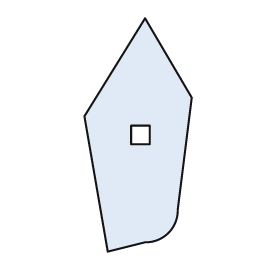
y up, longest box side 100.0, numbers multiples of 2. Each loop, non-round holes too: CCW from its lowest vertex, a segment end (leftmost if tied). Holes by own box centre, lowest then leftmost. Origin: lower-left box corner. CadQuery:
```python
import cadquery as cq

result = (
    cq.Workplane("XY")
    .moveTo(10.0, 0.0)
    .lineTo(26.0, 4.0)
    .threePointArc((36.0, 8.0), (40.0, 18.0))
    .lineTo(46.0, 66.0)
    .lineTo(26.0, 100.0)
    .lineTo(0.0, 58.0)
    .close()
    .moveTo(20.0, 46.0)
    .lineTo(28.0, 46.0)
    .lineTo(28.0, 54.0)
    .lineTo(20.0, 54.0)
    .close()
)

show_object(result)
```